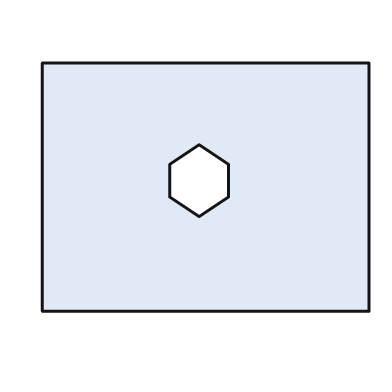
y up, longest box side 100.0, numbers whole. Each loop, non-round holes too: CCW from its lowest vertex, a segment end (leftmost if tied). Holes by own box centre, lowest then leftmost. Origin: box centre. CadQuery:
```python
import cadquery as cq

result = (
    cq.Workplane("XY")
    .moveTo(-50.0, -38.0)
    .lineTo(50.0, -38.0)
    .lineTo(50.0, 38.0)
    .lineTo(-50.0, 38.0)
    .close()
    .moveTo(-2.0, -9.0)
    .lineTo(7.0, -3.0)
    .lineTo(7.0, 7.0)
    .lineTo(-2.0, 13.0)
    .lineTo(-11.0, 7.0)
    .lineTo(-11.0, -3.0)
    .close()
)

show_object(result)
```